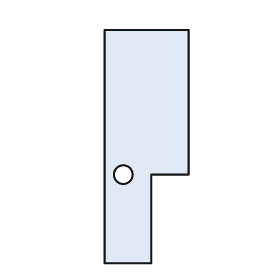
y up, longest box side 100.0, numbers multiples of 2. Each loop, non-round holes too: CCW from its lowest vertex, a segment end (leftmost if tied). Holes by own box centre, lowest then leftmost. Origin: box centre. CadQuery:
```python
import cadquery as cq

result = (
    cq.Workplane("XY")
    .moveTo(-18.0, -50.0)
    .lineTo(2.0, -50.0)
    .lineTo(2.0, -12.0)
    .lineTo(18.0, -12.0)
    .lineTo(18.0, 50.0)
    .lineTo(-18.0, 50.0)
    .close()
    .moveTo(-10.0, -12.0)
    .circle(4.0)
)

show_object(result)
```